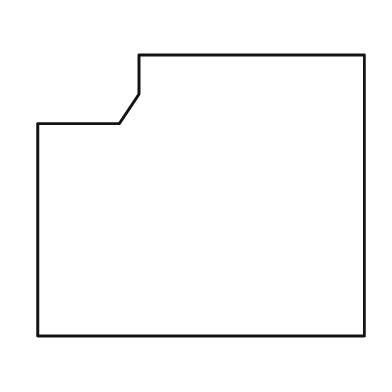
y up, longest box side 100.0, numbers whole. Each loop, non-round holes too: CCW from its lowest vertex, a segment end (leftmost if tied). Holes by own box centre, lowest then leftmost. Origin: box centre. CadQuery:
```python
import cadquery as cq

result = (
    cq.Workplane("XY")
    .moveTo(-50.0, -43.0)
    .lineTo(50.0, -43.0)
    .lineTo(50.0, 43.0)
    .lineTo(-19.0, 43.0)
    .lineTo(-19.0, 31.0)
    .lineTo(-25.0, 22.0)
    .lineTo(-50.0, 22.0)
    .close()
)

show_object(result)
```